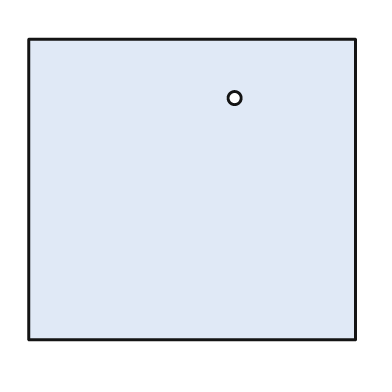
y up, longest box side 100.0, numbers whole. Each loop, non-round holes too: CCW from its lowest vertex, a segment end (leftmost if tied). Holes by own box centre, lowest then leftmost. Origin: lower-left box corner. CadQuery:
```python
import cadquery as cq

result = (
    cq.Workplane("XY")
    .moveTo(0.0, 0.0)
    .lineTo(100.0, 0.0)
    .lineTo(100.0, 92.0)
    .lineTo(0.0, 92.0)
    .close()
    .moveTo(63.0, 74.0)
    .circle(2.0)
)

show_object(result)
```